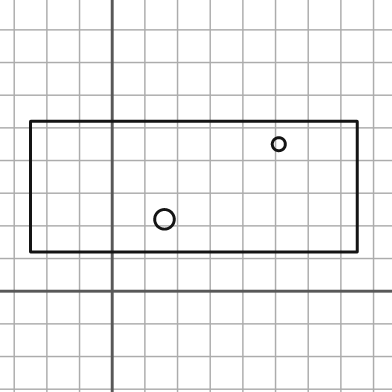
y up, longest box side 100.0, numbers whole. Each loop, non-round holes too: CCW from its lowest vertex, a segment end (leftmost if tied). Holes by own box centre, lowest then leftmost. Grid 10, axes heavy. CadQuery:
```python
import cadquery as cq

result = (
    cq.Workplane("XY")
    .moveTo(-25.0, 12.0)
    .lineTo(75.0, 12.0)
    .lineTo(75.0, 52.0)
    .lineTo(-25.0, 52.0)
    .close()
    .moveTo(16.0, 22.0)
    .circle(3.0)
    .moveTo(51.0, 45.0)
    .circle(2.0)
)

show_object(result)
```